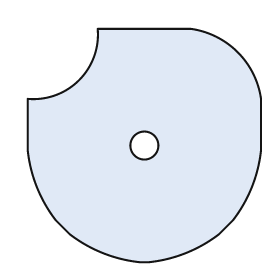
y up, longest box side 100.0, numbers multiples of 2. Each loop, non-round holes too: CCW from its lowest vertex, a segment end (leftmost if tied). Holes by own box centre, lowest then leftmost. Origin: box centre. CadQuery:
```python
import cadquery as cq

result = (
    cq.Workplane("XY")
    .moveTo(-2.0, -50.0)
    .lineTo(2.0, -50.0)
    .threePointArc((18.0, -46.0), (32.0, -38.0))
    .lineTo(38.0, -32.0)
    .threePointArc((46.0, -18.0), (50.0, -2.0))
    .lineTo(50.0, 20.0)
    .threePointArc((40.0, 40.0), (20.0, 50.0))
    .lineTo(-20.0, 50.0)
    .threePointArc((-28.0, 28.0), (-50.0, 20.0))
    .lineTo(-50.0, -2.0)
    .threePointArc((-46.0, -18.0), (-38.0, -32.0))
    .lineTo(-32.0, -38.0)
    .threePointArc((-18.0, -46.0), (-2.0, -50.0))
    .close()
    .moveTo(0.0, 0.0)
    .circle(6.0)
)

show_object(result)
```